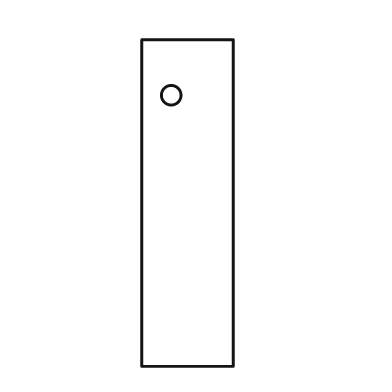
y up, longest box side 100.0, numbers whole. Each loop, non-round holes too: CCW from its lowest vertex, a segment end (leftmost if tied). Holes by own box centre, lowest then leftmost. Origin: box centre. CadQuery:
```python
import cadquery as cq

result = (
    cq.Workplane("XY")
    .moveTo(-14.0, -50.0)
    .lineTo(14.0, -50.0)
    .lineTo(14.0, 50.0)
    .lineTo(-14.0, 50.0)
    .close()
    .moveTo(-5.0, 33.0)
    .circle(3.0)
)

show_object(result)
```